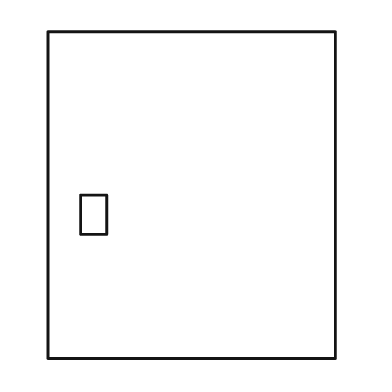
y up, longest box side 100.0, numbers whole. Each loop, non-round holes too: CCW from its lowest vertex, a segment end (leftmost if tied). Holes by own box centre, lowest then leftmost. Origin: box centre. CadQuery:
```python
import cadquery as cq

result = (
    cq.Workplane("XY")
    .moveTo(-44.0, -50.0)
    .lineTo(44.0, -50.0)
    .lineTo(44.0, 50.0)
    .lineTo(-44.0, 50.0)
    .close()
    .moveTo(-34.0, -12.0)
    .lineTo(-26.0, -12.0)
    .lineTo(-26.0, 0.0)
    .lineTo(-34.0, 0.0)
    .close()
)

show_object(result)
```